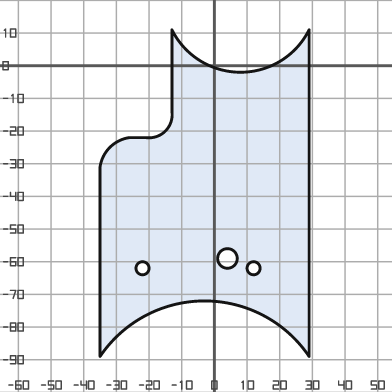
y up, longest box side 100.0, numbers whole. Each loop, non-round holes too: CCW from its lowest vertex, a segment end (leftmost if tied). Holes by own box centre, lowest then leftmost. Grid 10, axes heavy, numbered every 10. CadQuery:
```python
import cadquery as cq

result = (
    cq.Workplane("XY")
    .moveTo(-35.0, -89.0)
    .threePointArc((-3.0, -72.0), (29.0, -89.0))
    .lineTo(29.0, 11.0)
    .threePointArc((8.0, -2.0), (-13.0, 11.0))
    .lineTo(-13.0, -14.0)
    .threePointArc((-15.0, -20.0), (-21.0, -22.0))
    .lineTo(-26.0, -22.0)
    .threePointArc((-32.0, -25.0), (-35.0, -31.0))
    .close()
    .moveTo(-22.0, -62.0)
    .circle(2.0)
    .moveTo(12.0, -62.0)
    .circle(2.0)
    .moveTo(4.0, -59.0)
    .circle(3.0)
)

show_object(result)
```